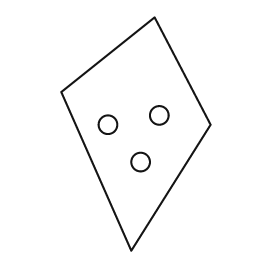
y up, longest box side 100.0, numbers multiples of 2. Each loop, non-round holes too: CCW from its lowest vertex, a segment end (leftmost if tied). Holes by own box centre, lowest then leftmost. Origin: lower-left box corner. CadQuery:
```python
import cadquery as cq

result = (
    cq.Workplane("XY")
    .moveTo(30.0, 0.0)
    .lineTo(64.0, 54.0)
    .lineTo(40.0, 100.0)
    .lineTo(0.0, 68.0)
    .close()
    .moveTo(34.0, 38.0)
    .circle(4.0)
    .moveTo(20.0, 54.0)
    .circle(4.0)
    .moveTo(42.0, 58.0)
    .circle(4.0)
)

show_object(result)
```